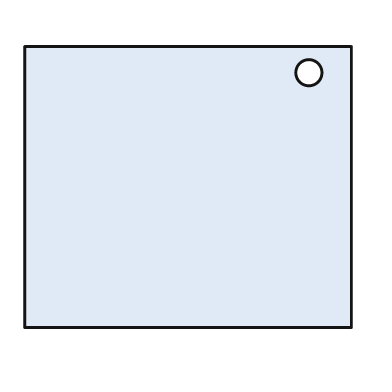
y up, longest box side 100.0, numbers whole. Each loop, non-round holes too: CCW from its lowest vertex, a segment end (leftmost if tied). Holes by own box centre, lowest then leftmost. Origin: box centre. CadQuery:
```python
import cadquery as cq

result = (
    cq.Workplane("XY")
    .moveTo(-50.0, -43.0)
    .lineTo(50.0, -43.0)
    .lineTo(50.0, 43.0)
    .lineTo(-50.0, 43.0)
    .close()
    .moveTo(37.0, 35.0)
    .circle(4.0)
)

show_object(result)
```